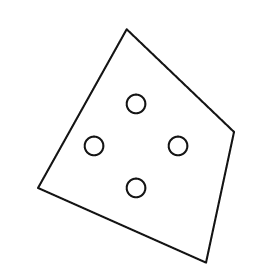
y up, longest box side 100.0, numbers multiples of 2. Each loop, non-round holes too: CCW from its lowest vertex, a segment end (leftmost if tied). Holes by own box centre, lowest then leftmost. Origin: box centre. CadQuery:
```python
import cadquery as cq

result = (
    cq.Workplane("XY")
    .moveTo(30.0, -50.0)
    .lineTo(42.0, 6.0)
    .lineTo(-4.0, 50.0)
    .lineTo(-42.0, -18.0)
    .close()
    .moveTo(0.0, -18.0)
    .circle(4.0)
    .moveTo(-18.0, 0.0)
    .circle(4.0)
    .moveTo(18.0, 0.0)
    .circle(4.0)
    .moveTo(0.0, 18.0)
    .circle(4.0)
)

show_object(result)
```